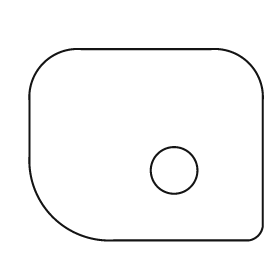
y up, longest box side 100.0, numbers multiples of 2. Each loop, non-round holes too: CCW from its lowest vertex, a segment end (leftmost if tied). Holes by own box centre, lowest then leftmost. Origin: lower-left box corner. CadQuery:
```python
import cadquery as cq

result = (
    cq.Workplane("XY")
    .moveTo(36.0, 0.0)
    .lineTo(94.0, 0.0)
    .threePointArc((98.0, 2.0), (100.0, 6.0))
    .lineTo(100.0, 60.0)
    .threePointArc((94.0, 76.0), (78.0, 82.0))
    .lineTo(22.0, 82.0)
    .threePointArc((6.0, 76.0), (0.0, 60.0))
    .lineTo(0.0, 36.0)
    .threePointArc((10.0, 10.0), (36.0, 0.0))
    .close()
    .moveTo(62.0, 30.0)
    .circle(10.0)
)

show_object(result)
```